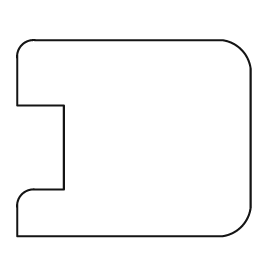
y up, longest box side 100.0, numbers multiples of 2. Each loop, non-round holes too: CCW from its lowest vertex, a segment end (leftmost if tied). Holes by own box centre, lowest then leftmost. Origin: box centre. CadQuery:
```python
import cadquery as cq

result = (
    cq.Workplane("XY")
    .moveTo(-50.0, -42.0)
    .lineTo(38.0, -42.0)
    .threePointArc((46.0, -38.0), (50.0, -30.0))
    .lineTo(50.0, 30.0)
    .threePointArc((46.0, 38.0), (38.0, 42.0))
    .lineTo(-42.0, 42.0)
    .threePointArc((-48.0, 40.0), (-50.0, 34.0))
    .lineTo(-50.0, 14.0)
    .lineTo(-30.0, 14.0)
    .lineTo(-30.0, -22.0)
    .lineTo(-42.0, -22.0)
    .threePointArc((-48.0, -24.0), (-50.0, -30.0))
    .close()
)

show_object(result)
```